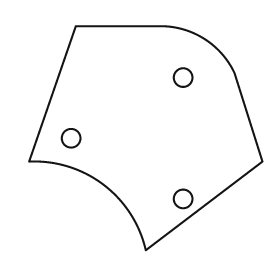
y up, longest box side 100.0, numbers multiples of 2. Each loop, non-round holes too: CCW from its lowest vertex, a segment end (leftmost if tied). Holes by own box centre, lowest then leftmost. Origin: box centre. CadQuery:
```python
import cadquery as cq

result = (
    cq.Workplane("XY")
    .moveTo(0.0, -48.0)
    .lineTo(50.0, -10.0)
    .lineTo(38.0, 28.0)
    .threePointArc((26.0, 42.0), (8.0, 48.0))
    .lineTo(-30.0, 48.0)
    .lineTo(-50.0, -10.0)
    .threePointArc((-18.0, -20.0), (0.0, -48.0))
    .close()
    .moveTo(16.0, -26.0)
    .circle(4.0)
    .moveTo(-32.0, 0.0)
    .circle(4.0)
    .moveTo(16.0, 26.0)
    .circle(4.0)
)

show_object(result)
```